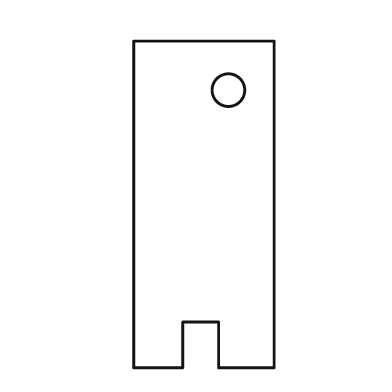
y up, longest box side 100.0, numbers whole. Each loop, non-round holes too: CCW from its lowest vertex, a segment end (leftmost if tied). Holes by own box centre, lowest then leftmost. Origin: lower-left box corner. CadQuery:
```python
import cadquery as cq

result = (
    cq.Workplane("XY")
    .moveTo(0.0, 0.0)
    .lineTo(15.0, 0.0)
    .lineTo(15.0, 14.0)
    .lineTo(26.0, 14.0)
    .lineTo(26.0, 0.0)
    .lineTo(43.0, 0.0)
    .lineTo(43.0, 100.0)
    .lineTo(0.0, 100.0)
    .close()
    .moveTo(29.0, 85.0)
    .circle(5.0)
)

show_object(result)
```